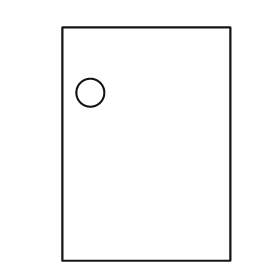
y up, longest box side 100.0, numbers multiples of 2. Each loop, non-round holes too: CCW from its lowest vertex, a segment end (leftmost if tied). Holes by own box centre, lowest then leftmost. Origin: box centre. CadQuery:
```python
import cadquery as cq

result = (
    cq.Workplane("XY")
    .moveTo(-36.0, -50.0)
    .lineTo(36.0, -50.0)
    .lineTo(36.0, 50.0)
    .lineTo(-36.0, 50.0)
    .close()
    .moveTo(-24.0, 22.0)
    .circle(6.0)
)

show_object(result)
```